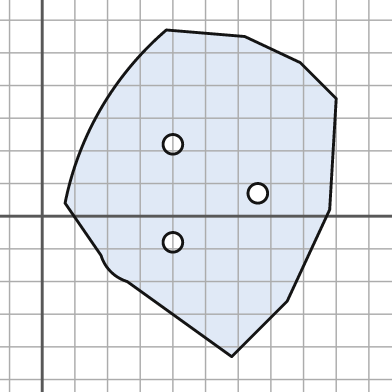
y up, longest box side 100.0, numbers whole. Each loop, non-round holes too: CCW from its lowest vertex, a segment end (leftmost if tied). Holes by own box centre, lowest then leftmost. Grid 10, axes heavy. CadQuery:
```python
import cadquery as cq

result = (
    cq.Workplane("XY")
    .moveTo(58.0, -43.0)
    .lineTo(75.0, -26.0)
    .lineTo(88.0, 2.0)
    .lineTo(90.0, 36.0)
    .lineTo(79.0, 47.0)
    .lineTo(62.0, 55.0)
    .lineTo(38.0, 57.0)
    .threePointArc((18.0, 33.0), (7.0, 4.0))
    .lineTo(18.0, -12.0)
    .threePointArc((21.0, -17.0), (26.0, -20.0))
    .close()
    .moveTo(40.0, -8.0)
    .circle(3.0)
    .moveTo(66.0, 7.0)
    .circle(3.0)
    .moveTo(40.0, 22.0)
    .circle(3.0)
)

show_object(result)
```